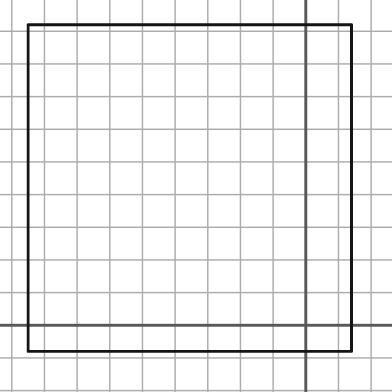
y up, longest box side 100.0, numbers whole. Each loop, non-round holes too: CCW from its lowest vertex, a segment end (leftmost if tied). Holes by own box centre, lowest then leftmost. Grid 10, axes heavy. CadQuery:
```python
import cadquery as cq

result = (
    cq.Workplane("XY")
    .moveTo(-85.0, -8.0)
    .lineTo(14.0, -8.0)
    .lineTo(14.0, 92.0)
    .lineTo(-85.0, 92.0)
    .close()
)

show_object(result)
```